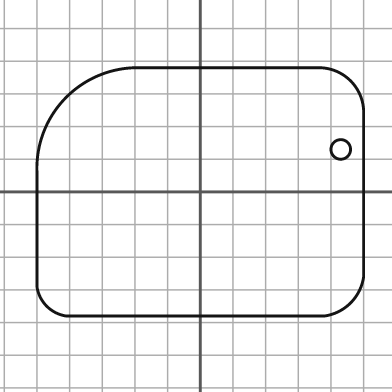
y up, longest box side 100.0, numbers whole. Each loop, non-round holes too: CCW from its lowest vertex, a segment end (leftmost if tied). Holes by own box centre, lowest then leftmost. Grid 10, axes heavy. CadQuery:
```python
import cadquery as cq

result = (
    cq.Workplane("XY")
    .moveTo(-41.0, -38.0)
    .lineTo(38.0, -38.0)
    .threePointArc((46.0, -34.0), (50.0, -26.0))
    .lineTo(50.0, 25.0)
    .threePointArc((46.0, 34.0), (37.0, 38.0))
    .lineTo(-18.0, 38.0)
    .threePointArc((-41.0, 29.0), (-50.0, 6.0))
    .lineTo(-50.0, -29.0)
    .threePointArc((-47.0, -35.0), (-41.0, -38.0))
    .close()
    .moveTo(43.0, 13.0)
    .circle(3.0)
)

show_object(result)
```